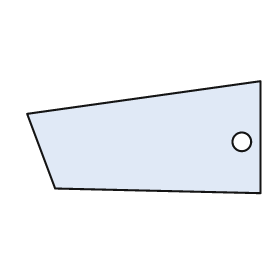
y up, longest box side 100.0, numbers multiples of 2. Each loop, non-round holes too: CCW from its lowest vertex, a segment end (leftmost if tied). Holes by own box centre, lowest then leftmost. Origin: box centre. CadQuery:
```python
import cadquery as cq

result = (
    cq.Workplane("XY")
    .moveTo(50.0, -24.0)
    .lineTo(50.0, 24.0)
    .lineTo(-50.0, 10.0)
    .lineTo(-38.0, -22.0)
    .close()
    .moveTo(42.0, -2.0)
    .circle(4.0)
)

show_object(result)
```